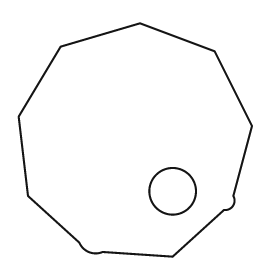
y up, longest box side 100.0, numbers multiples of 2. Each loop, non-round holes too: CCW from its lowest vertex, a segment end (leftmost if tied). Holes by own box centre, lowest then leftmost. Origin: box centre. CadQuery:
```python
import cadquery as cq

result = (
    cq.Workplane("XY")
    .moveTo(16.0, -50.0)
    .lineTo(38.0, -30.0)
    .threePointArc((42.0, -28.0), (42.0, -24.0))
    .lineTo(50.0, 6.0)
    .lineTo(34.0, 38.0)
    .lineTo(2.0, 50.0)
    .lineTo(-32.0, 40.0)
    .lineTo(-50.0, 10.0)
    .lineTo(-46.0, -24.0)
    .lineTo(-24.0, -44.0)
    .threePointArc((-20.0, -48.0), (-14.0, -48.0))
    .close()
    .moveTo(16.0, -22.0)
    .circle(10.0)
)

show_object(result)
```